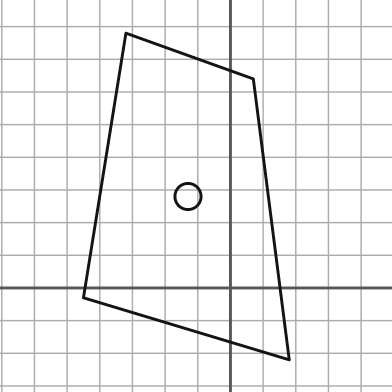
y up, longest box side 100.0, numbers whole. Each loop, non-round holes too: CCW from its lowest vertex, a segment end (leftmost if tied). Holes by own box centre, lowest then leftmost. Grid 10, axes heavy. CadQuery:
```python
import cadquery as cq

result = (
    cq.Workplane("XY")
    .moveTo(18.0, -22.0)
    .lineTo(7.0, 64.0)
    .lineTo(-32.0, 78.0)
    .lineTo(-45.0, -3.0)
    .close()
    .moveTo(-13.0, 28.0)
    .circle(4.0)
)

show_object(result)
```